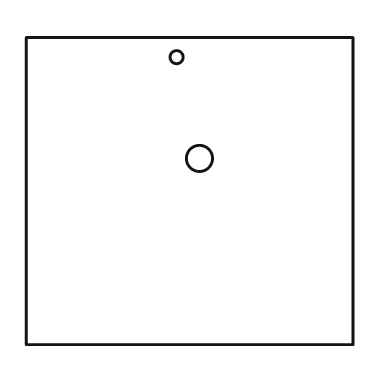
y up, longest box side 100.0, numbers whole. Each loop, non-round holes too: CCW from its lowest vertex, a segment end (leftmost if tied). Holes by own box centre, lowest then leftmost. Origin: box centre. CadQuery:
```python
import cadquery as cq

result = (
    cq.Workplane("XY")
    .moveTo(-50.0, -47.0)
    .lineTo(50.0, -47.0)
    .lineTo(50.0, 47.0)
    .lineTo(-50.0, 47.0)
    .close()
    .moveTo(3.0, 10.0)
    .circle(4.0)
    .moveTo(-4.0, 41.0)
    .circle(2.0)
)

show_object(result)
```